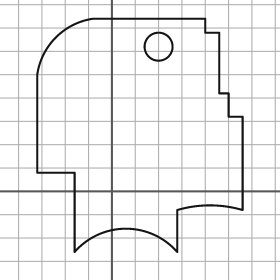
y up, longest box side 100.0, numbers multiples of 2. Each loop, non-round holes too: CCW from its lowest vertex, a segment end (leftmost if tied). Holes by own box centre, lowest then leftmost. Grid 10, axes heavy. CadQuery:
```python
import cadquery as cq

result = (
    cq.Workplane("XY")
    .moveTo(-16.0, -26.0)
    .threePointArc((6.0, -16.0), (28.0, -26.0))
    .lineTo(28.0, -8.0)
    .threePointArc((42.0, -6.0), (56.0, -8.0))
    .lineTo(56.0, 32.0)
    .lineTo(50.0, 32.0)
    .lineTo(50.0, 42.0)
    .lineTo(46.0, 42.0)
    .lineTo(46.0, 68.0)
    .lineTo(40.0, 68.0)
    .lineTo(40.0, 74.0)
    .lineTo(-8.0, 74.0)
    .threePointArc((-24.0, 66.0), (-32.0, 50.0))
    .lineTo(-32.0, 8.0)
    .lineTo(-16.0, 8.0)
    .close()
    .moveTo(20.0, 62.0)
    .circle(6.0)
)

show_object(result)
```